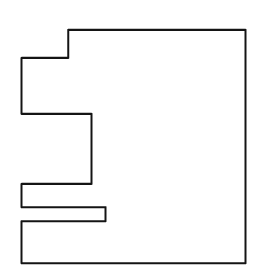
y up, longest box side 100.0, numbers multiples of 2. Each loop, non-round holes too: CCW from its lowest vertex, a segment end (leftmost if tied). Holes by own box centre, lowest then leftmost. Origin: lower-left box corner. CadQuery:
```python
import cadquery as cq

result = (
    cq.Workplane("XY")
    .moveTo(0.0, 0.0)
    .lineTo(96.0, 0.0)
    .lineTo(96.0, 100.0)
    .lineTo(20.0, 100.0)
    .lineTo(20.0, 88.0)
    .lineTo(0.0, 88.0)
    .lineTo(0.0, 64.0)
    .lineTo(30.0, 64.0)
    .lineTo(30.0, 34.0)
    .lineTo(0.0, 34.0)
    .lineTo(0.0, 24.0)
    .lineTo(36.0, 24.0)
    .lineTo(36.0, 18.0)
    .lineTo(0.0, 18.0)
    .close()
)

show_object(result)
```